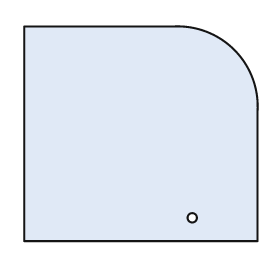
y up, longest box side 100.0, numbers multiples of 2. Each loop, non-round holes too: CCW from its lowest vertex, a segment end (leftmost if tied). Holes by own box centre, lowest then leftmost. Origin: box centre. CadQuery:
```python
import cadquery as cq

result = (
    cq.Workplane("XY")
    .moveTo(-50.0, -46.0)
    .lineTo(50.0, -46.0)
    .lineTo(50.0, 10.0)
    .threePointArc((40.0, 36.0), (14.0, 46.0))
    .lineTo(-50.0, 46.0)
    .close()
    .moveTo(22.0, -36.0)
    .circle(2.0)
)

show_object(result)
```